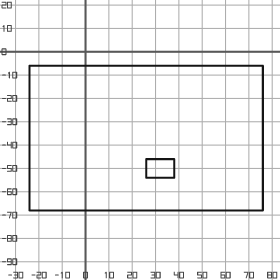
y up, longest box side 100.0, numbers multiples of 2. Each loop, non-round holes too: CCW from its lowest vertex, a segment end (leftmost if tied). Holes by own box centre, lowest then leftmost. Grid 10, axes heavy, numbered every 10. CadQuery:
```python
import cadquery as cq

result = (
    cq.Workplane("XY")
    .moveTo(-24.0, -68.0)
    .lineTo(76.0, -68.0)
    .lineTo(76.0, -6.0)
    .lineTo(-24.0, -6.0)
    .close()
    .moveTo(26.0, -54.0)
    .lineTo(38.0, -54.0)
    .lineTo(38.0, -46.0)
    .lineTo(26.0, -46.0)
    .close()
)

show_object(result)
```